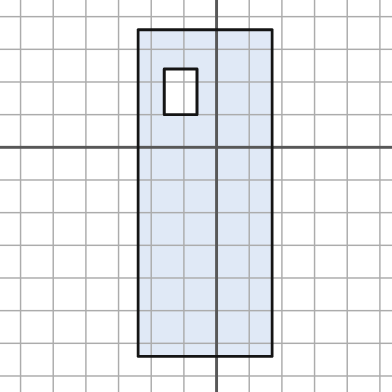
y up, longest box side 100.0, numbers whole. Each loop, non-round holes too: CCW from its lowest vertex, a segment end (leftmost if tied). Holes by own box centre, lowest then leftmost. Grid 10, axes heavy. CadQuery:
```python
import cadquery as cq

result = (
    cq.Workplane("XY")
    .moveTo(-24.0, -64.0)
    .lineTo(17.0, -64.0)
    .lineTo(17.0, 36.0)
    .lineTo(-24.0, 36.0)
    .close()
    .moveTo(-16.0, 10.0)
    .lineTo(-6.0, 10.0)
    .lineTo(-6.0, 24.0)
    .lineTo(-16.0, 24.0)
    .close()
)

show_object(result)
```